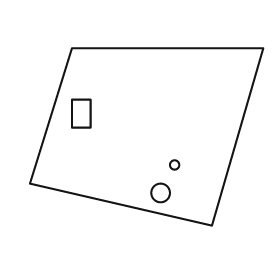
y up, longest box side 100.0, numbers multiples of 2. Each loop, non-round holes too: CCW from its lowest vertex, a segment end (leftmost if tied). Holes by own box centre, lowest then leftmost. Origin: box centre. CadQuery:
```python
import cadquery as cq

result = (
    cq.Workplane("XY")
    .moveTo(28.0, -38.0)
    .lineTo(50.0, 38.0)
    .lineTo(-32.0, 38.0)
    .lineTo(-50.0, -20.0)
    .close()
    .moveTo(6.0, -24.0)
    .circle(4.0)
    .moveTo(12.0, -12.0)
    .circle(2.0)
    .moveTo(-32.0, 4.0)
    .lineTo(-24.0, 4.0)
    .lineTo(-24.0, 16.0)
    .lineTo(-32.0, 16.0)
    .close()
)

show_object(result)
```